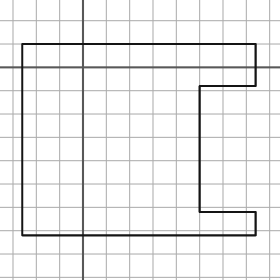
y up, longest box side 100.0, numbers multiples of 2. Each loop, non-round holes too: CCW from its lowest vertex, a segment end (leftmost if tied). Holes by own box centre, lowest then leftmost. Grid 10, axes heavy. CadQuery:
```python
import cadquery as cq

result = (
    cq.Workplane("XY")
    .moveTo(-26.0, -72.0)
    .lineTo(74.0, -72.0)
    .lineTo(74.0, -62.0)
    .lineTo(50.0, -62.0)
    .lineTo(50.0, -8.0)
    .lineTo(74.0, -8.0)
    .lineTo(74.0, 10.0)
    .lineTo(-26.0, 10.0)
    .close()
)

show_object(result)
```